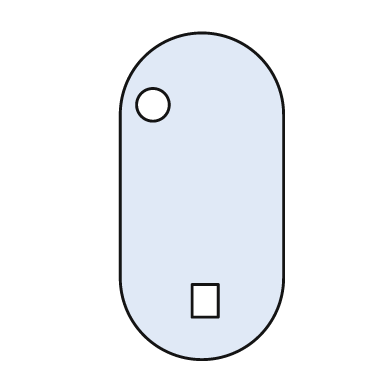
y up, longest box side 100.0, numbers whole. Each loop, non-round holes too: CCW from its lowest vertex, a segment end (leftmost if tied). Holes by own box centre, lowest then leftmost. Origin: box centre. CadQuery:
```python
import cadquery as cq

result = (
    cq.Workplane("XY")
    .moveTo(-25.0, -25.0)
    .threePointArc((0.0, -50.0), (25.0, -25.0))
    .lineTo(25.0, 25.0)
    .threePointArc((0.0, 50.0), (-25.0, 25.0))
    .close()
    .moveTo(-3.0, -37.0)
    .lineTo(5.0, -37.0)
    .lineTo(5.0, -27.0)
    .lineTo(-3.0, -27.0)
    .close()
    .moveTo(-15.0, 28.0)
    .circle(5.0)
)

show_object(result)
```